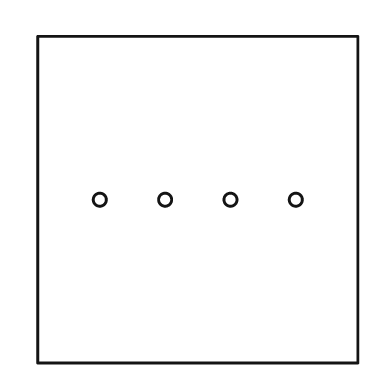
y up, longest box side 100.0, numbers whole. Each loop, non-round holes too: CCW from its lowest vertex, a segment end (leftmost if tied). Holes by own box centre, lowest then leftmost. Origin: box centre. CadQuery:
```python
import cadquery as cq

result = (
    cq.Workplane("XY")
    .moveTo(-49.0, -50.0)
    .lineTo(49.0, -50.0)
    .lineTo(49.0, 50.0)
    .lineTo(-49.0, 50.0)
    .close()
    .moveTo(-30.0, 0.0)
    .circle(2.0)
    .moveTo(-10.0, 0.0)
    .circle(2.0)
    .moveTo(10.0, 0.0)
    .circle(2.0)
    .moveTo(30.0, 0.0)
    .circle(2.0)
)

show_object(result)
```